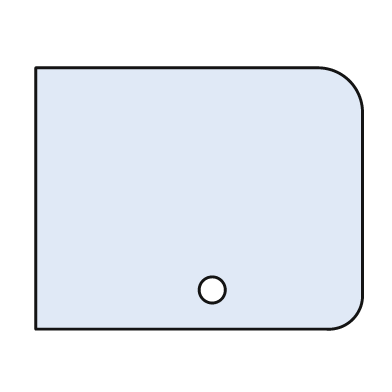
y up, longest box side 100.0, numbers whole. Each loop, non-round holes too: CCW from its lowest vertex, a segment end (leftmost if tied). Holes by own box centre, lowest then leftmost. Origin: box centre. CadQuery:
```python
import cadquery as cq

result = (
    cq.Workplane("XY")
    .moveTo(-50.0, -40.0)
    .lineTo(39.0, -40.0)
    .threePointArc((47.0, -37.0), (50.0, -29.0))
    .lineTo(50.0, 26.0)
    .threePointArc((46.0, 36.0), (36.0, 40.0))
    .lineTo(-50.0, 40.0)
    .close()
    .moveTo(4.0, -28.0)
    .circle(4.0)
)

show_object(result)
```